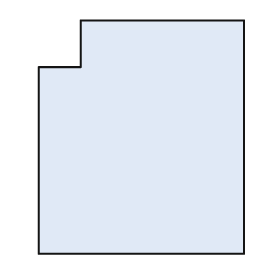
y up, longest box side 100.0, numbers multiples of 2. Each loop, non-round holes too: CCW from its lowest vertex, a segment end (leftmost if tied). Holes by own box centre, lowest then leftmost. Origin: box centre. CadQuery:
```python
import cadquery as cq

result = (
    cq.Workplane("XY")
    .moveTo(-44.0, -50.0)
    .lineTo(44.0, -50.0)
    .lineTo(44.0, 50.0)
    .lineTo(-26.0, 50.0)
    .lineTo(-26.0, 30.0)
    .lineTo(-44.0, 30.0)
    .close()
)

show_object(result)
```